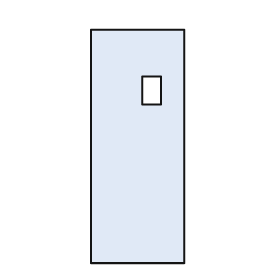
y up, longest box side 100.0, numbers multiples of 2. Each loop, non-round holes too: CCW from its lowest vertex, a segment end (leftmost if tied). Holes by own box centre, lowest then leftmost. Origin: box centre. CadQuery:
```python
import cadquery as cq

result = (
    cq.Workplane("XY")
    .moveTo(-20.0, -50.0)
    .lineTo(20.0, -50.0)
    .lineTo(20.0, 50.0)
    .lineTo(-20.0, 50.0)
    .close()
    .moveTo(2.0, 18.0)
    .lineTo(10.0, 18.0)
    .lineTo(10.0, 30.0)
    .lineTo(2.0, 30.0)
    .close()
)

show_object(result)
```